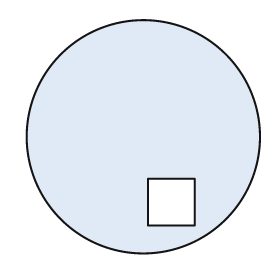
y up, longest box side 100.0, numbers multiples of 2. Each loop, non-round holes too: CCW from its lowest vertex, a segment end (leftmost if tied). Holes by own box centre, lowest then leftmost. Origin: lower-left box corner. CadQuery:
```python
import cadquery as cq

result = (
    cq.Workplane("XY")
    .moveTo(50.0, 50.0)
    .circle(50.0)
    .moveTo(52.0, 12.0)
    .lineTo(72.0, 12.0)
    .lineTo(72.0, 32.0)
    .lineTo(52.0, 32.0)
    .close()
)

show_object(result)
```